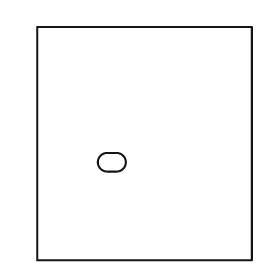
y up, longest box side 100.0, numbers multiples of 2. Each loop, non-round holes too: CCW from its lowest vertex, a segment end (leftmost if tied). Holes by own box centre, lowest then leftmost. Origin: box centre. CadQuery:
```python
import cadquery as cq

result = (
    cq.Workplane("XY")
    .moveTo(-46.0, -50.0)
    .lineTo(46.0, -50.0)
    .lineTo(46.0, 50.0)
    .lineTo(-46.0, 50.0)
    .close()
    .moveTo(-16.0, -12.0)
    .lineTo(-12.0, -12.0)
    .threePointArc((-8.0, -8.0), (-12.0, -4.0))
    .lineTo(-16.0, -4.0)
    .threePointArc((-20.0, -8.0), (-16.0, -12.0))
    .close()
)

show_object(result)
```